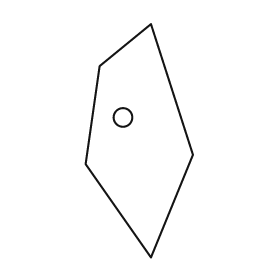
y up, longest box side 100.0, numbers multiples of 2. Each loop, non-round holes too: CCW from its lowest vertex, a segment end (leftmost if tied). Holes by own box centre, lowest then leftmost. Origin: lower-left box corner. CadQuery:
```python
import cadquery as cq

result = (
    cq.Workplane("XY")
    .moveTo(28.0, 0.0)
    .lineTo(46.0, 44.0)
    .lineTo(28.0, 100.0)
    .lineTo(6.0, 82.0)
    .lineTo(0.0, 40.0)
    .close()
    .moveTo(16.0, 60.0)
    .circle(4.0)
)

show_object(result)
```